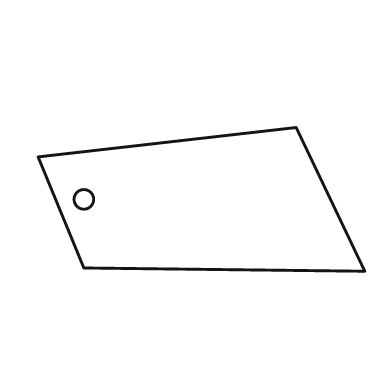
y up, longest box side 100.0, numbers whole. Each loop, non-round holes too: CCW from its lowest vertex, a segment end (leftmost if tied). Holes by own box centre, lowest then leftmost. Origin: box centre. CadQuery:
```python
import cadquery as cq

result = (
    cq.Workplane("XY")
    .moveTo(50.0, -22.0)
    .lineTo(29.0, 22.0)
    .lineTo(-50.0, 13.0)
    .lineTo(-36.0, -21.0)
    .close()
    .moveTo(-36.0, 0.0)
    .circle(3.0)
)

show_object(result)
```